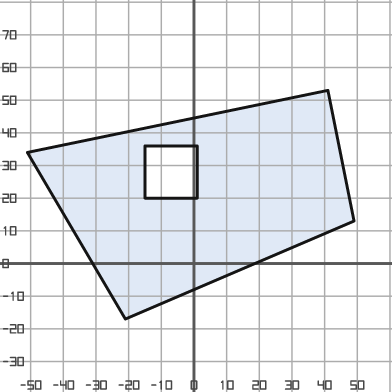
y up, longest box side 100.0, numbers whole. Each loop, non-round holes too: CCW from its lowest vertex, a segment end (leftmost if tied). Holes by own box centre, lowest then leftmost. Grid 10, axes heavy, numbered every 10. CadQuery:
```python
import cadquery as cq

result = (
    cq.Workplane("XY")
    .moveTo(-21.0, -17.0)
    .lineTo(49.0, 13.0)
    .lineTo(41.0, 53.0)
    .lineTo(-51.0, 34.0)
    .close()
    .moveTo(-15.0, 20.0)
    .lineTo(1.0, 20.0)
    .lineTo(1.0, 36.0)
    .lineTo(-15.0, 36.0)
    .close()
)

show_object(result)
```